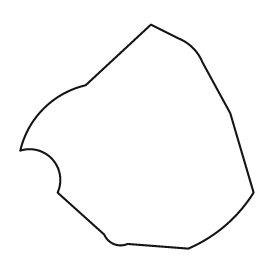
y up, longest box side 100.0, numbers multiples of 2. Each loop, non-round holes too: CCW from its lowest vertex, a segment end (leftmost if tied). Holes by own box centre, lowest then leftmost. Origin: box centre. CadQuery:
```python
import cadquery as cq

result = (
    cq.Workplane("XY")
    .moveTo(22.0, -48.0)
    .threePointArc((38.0, -38.0), (50.0, -24.0))
    .lineTo(40.0, 10.0)
    .lineTo(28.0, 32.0)
    .threePointArc((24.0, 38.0), (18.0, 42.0))
    .lineTo(6.0, 48.0)
    .lineTo(-22.0, 22.0)
    .threePointArc((-40.0, 12.0), (-50.0, -6.0))
    .threePointArc((-36.0, -10.0), (-34.0, -24.0))
    .lineTo(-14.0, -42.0)
    .threePointArc((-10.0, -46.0), (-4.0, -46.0))
    .close()
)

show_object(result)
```